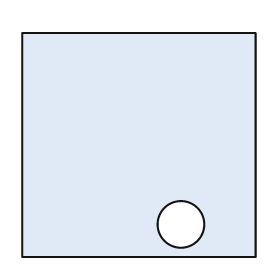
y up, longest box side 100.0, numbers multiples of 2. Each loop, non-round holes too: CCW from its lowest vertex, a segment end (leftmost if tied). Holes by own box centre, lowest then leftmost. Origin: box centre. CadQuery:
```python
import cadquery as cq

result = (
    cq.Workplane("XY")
    .moveTo(-50.0, -48.0)
    .lineTo(50.0, -48.0)
    .lineTo(50.0, 48.0)
    .lineTo(-50.0, 48.0)
    .close()
    .moveTo(18.0, -34.0)
    .circle(10.0)
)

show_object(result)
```